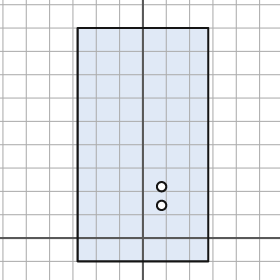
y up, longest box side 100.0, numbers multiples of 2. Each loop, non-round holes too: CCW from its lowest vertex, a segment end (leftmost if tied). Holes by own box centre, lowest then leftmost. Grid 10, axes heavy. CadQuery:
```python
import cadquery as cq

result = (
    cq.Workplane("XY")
    .moveTo(-28.0, -10.0)
    .lineTo(28.0, -10.0)
    .lineTo(28.0, 90.0)
    .lineTo(-28.0, 90.0)
    .close()
    .moveTo(8.0, 14.0)
    .circle(2.0)
    .moveTo(8.0, 22.0)
    .circle(2.0)
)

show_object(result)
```